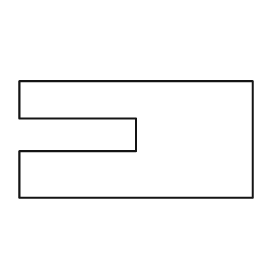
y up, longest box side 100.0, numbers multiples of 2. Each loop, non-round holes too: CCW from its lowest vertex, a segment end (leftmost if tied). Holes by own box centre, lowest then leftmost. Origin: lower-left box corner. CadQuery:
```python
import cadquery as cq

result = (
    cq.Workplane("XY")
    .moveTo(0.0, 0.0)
    .lineTo(100.0, 0.0)
    .lineTo(100.0, 50.0)
    .lineTo(0.0, 50.0)
    .lineTo(0.0, 34.0)
    .lineTo(50.0, 34.0)
    .lineTo(50.0, 20.0)
    .lineTo(0.0, 20.0)
    .close()
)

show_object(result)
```